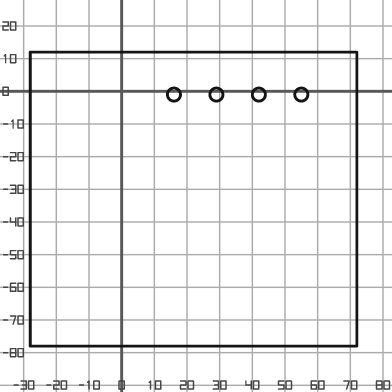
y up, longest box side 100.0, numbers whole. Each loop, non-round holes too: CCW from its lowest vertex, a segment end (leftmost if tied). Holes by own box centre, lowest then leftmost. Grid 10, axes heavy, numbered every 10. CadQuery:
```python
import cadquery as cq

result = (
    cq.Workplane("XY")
    .moveTo(-28.0, -78.0)
    .lineTo(72.0, -78.0)
    .lineTo(72.0, 12.0)
    .lineTo(-28.0, 12.0)
    .close()
    .moveTo(16.0, -1.0)
    .circle(2.0)
    .moveTo(29.0, -1.0)
    .circle(2.0)
    .moveTo(42.0, -1.0)
    .circle(2.0)
    .moveTo(55.0, -1.0)
    .circle(2.0)
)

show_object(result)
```